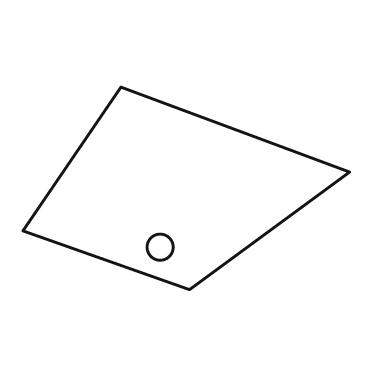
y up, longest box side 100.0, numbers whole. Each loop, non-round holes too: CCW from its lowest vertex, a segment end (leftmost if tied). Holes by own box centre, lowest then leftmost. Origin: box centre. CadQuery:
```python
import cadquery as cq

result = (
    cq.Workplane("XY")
    .moveTo(1.0, -31.0)
    .lineTo(50.0, 5.0)
    .lineTo(-20.0, 31.0)
    .lineTo(-50.0, -13.0)
    .close()
    .moveTo(-8.0, -18.0)
    .circle(4.0)
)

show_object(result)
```